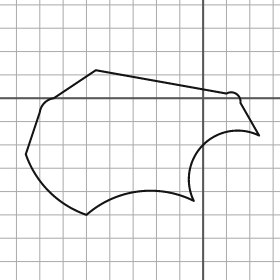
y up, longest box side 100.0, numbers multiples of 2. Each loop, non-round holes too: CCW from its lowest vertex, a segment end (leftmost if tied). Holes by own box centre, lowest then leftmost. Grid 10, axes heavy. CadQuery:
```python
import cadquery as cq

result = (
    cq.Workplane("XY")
    .moveTo(-50.0, -50.0)
    .threePointArc((-28.0, -40.0), (-4.0, -44.0))
    .threePointArc((0.0, -20.0), (24.0, -16.0))
    .lineTo(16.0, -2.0)
    .threePointArc((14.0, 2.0), (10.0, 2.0))
    .lineTo(-46.0, 12.0)
    .lineTo(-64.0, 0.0)
    .threePointArc((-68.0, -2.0), (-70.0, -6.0))
    .lineTo(-76.0, -24.0)
    .threePointArc((-66.0, -40.0), (-50.0, -50.0))
    .close()
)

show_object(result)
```